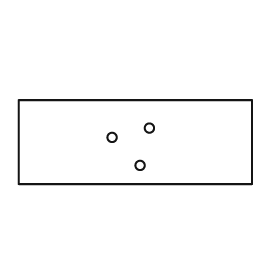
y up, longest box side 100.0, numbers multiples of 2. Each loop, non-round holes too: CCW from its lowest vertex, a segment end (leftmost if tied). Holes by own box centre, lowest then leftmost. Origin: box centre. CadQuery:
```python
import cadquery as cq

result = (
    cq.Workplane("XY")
    .moveTo(-50.0, -18.0)
    .lineTo(50.0, -18.0)
    .lineTo(50.0, 18.0)
    .lineTo(-50.0, 18.0)
    .close()
    .moveTo(2.0, -10.0)
    .circle(2.0)
    .moveTo(-10.0, 2.0)
    .circle(2.0)
    .moveTo(6.0, 6.0)
    .circle(2.0)
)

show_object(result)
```